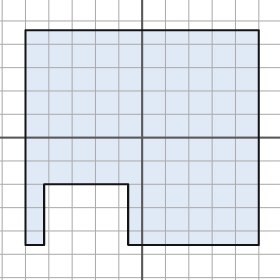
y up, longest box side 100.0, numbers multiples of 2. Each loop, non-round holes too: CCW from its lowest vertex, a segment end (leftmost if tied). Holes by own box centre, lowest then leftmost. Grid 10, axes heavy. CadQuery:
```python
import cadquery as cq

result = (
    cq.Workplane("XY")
    .moveTo(-50.0, -46.0)
    .lineTo(-42.0, -46.0)
    .lineTo(-42.0, -20.0)
    .lineTo(-6.0, -20.0)
    .lineTo(-6.0, -46.0)
    .lineTo(50.0, -46.0)
    .lineTo(50.0, 46.0)
    .lineTo(-50.0, 46.0)
    .close()
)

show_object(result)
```